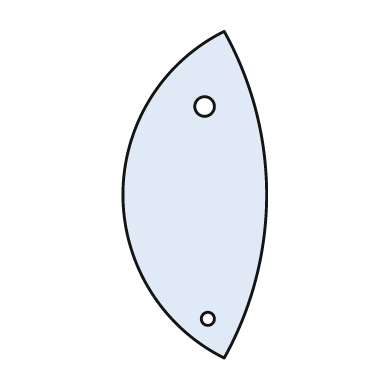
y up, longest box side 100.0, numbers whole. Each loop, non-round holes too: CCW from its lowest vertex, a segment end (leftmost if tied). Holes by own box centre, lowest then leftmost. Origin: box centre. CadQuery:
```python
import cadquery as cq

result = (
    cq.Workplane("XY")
    .moveTo(9.0, -50.0)
    .threePointArc((22.0, 0.0), (9.0, 50.0))
    .threePointArc((-22.0, 0.0), (9.0, -50.0))
    .close()
    .moveTo(4.0, -38.0)
    .circle(2.0)
    .moveTo(3.0, 27.0)
    .circle(3.0)
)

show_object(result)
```